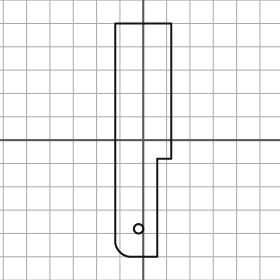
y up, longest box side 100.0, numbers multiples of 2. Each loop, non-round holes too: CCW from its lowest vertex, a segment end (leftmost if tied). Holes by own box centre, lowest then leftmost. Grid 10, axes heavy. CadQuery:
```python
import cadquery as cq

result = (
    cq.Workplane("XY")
    .moveTo(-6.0, -50.0)
    .lineTo(6.0, -50.0)
    .lineTo(6.0, -8.0)
    .lineTo(12.0, -8.0)
    .lineTo(12.0, 50.0)
    .lineTo(-12.0, 50.0)
    .lineTo(-12.0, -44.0)
    .threePointArc((-10.0, -48.0), (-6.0, -50.0))
    .close()
    .moveTo(-2.0, -38.0)
    .circle(2.0)
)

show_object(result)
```